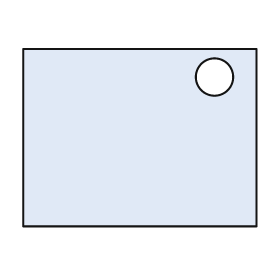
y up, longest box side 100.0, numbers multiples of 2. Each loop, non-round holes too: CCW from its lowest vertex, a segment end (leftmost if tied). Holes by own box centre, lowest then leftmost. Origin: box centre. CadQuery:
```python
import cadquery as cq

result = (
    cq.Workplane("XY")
    .moveTo(-50.0, -38.0)
    .lineTo(50.0, -38.0)
    .lineTo(50.0, 38.0)
    .lineTo(-50.0, 38.0)
    .close()
    .moveTo(32.0, 26.0)
    .circle(8.0)
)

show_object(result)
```